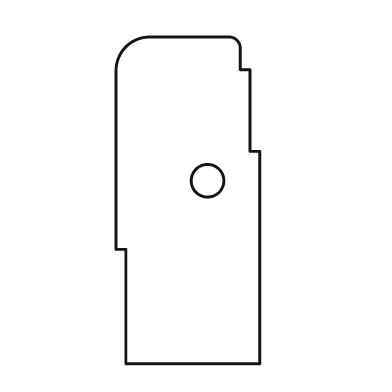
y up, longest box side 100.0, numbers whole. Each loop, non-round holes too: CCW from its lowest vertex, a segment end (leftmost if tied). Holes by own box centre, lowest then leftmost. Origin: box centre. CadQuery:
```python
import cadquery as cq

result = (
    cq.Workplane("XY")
    .moveTo(-19.0, -50.0)
    .lineTo(22.0, -50.0)
    .lineTo(22.0, 15.0)
    .lineTo(19.0, 15.0)
    .lineTo(19.0, 40.0)
    .lineTo(16.0, 40.0)
    .lineTo(16.0, 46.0)
    .threePointArc((15.0, 49.0), (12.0, 50.0))
    .lineTo(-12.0, 50.0)
    .threePointArc((-19.0, 47.0), (-22.0, 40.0))
    .lineTo(-22.0, -15.0)
    .lineTo(-19.0, -15.0)
    .close()
    .moveTo(6.0, 6.0)
    .circle(5.0)
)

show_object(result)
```